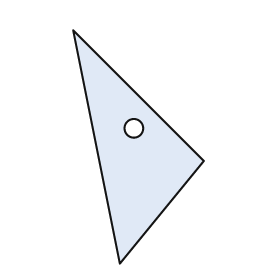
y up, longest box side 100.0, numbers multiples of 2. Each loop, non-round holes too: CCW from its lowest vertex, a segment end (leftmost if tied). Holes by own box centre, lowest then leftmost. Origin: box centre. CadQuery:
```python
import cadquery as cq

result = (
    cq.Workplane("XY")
    .moveTo(-8.0, -50.0)
    .lineTo(28.0, -6.0)
    .lineTo(-28.0, 50.0)
    .close()
    .moveTo(-2.0, 8.0)
    .circle(4.0)
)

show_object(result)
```